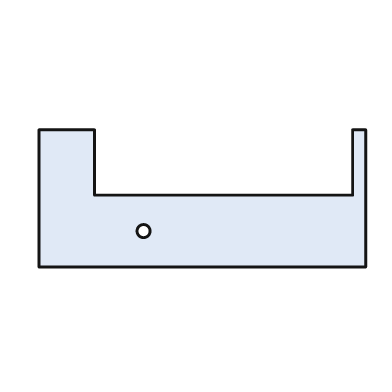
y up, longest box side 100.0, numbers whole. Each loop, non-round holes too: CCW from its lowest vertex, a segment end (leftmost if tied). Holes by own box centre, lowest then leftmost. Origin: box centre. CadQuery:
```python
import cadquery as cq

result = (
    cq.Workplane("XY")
    .moveTo(-50.0, -21.0)
    .lineTo(50.0, -21.0)
    .lineTo(50.0, 21.0)
    .lineTo(46.0, 21.0)
    .lineTo(46.0, 1.0)
    .lineTo(-33.0, 1.0)
    .lineTo(-33.0, 21.0)
    .lineTo(-50.0, 21.0)
    .close()
    .moveTo(-18.0, -10.0)
    .circle(2.0)
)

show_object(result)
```